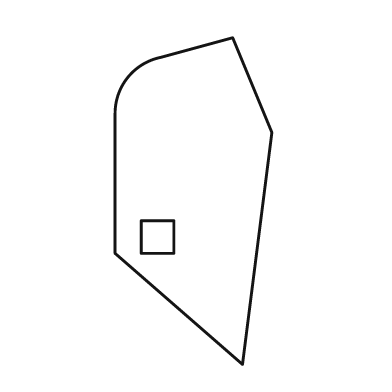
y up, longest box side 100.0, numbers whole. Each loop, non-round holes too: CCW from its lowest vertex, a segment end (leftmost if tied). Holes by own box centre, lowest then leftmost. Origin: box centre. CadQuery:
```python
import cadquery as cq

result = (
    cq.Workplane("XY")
    .moveTo(15.0, -50.0)
    .lineTo(24.0, 21.0)
    .lineTo(12.0, 50.0)
    .lineTo(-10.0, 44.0)
    .threePointArc((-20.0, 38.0), (-24.0, 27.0))
    .lineTo(-24.0, -16.0)
    .close()
    .moveTo(-16.0, -16.0)
    .lineTo(-6.0, -16.0)
    .lineTo(-6.0, -6.0)
    .lineTo(-16.0, -6.0)
    .close()
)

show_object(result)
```